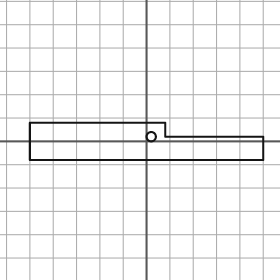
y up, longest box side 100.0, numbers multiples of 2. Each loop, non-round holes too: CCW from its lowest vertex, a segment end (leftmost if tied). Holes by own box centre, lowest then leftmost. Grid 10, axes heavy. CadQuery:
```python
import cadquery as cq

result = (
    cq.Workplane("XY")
    .moveTo(-50.0, -8.0)
    .lineTo(50.0, -8.0)
    .lineTo(50.0, 2.0)
    .lineTo(8.0, 2.0)
    .lineTo(8.0, 8.0)
    .lineTo(-50.0, 8.0)
    .close()
    .moveTo(2.0, 2.0)
    .circle(2.0)
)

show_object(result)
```